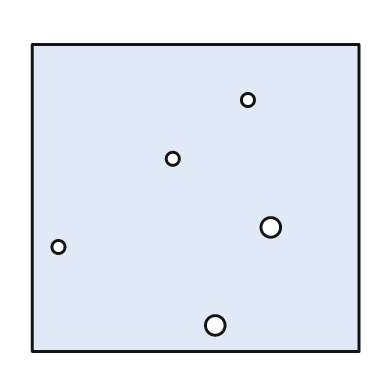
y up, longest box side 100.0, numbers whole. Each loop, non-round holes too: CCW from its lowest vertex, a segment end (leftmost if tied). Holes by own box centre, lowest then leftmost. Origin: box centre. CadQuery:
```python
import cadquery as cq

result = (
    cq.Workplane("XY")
    .moveTo(-50.0, -47.0)
    .lineTo(50.0, -47.0)
    .lineTo(50.0, 47.0)
    .lineTo(-50.0, 47.0)
    .close()
    .moveTo(6.0, -39.0)
    .circle(3.0)
    .moveTo(-42.0, -15.0)
    .circle(2.0)
    .moveTo(23.0, -9.0)
    .circle(3.0)
    .moveTo(-7.0, 12.0)
    .circle(2.0)
    .moveTo(16.0, 30.0)
    .circle(2.0)
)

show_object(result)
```